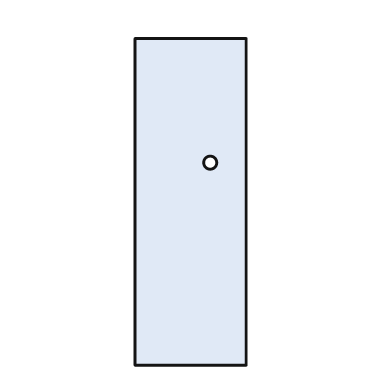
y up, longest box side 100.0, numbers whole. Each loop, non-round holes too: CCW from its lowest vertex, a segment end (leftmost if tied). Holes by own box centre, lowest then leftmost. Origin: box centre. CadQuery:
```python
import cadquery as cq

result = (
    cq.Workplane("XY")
    .moveTo(-17.0, -50.0)
    .lineTo(17.0, -50.0)
    .lineTo(17.0, 50.0)
    .lineTo(-17.0, 50.0)
    .close()
    .moveTo(6.0, 12.0)
    .circle(2.0)
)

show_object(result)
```